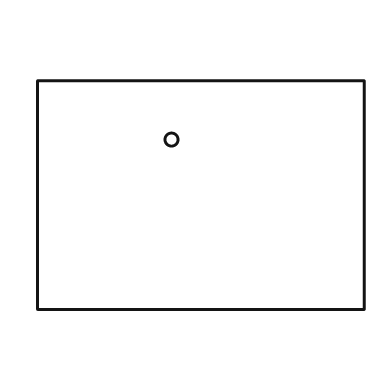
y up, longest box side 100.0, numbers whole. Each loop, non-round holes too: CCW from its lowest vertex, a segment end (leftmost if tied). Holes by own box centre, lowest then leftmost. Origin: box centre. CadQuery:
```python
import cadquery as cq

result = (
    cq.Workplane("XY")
    .moveTo(-50.0, -35.0)
    .lineTo(50.0, -35.0)
    .lineTo(50.0, 35.0)
    .lineTo(-50.0, 35.0)
    .close()
    .moveTo(-9.0, 17.0)
    .circle(2.0)
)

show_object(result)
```